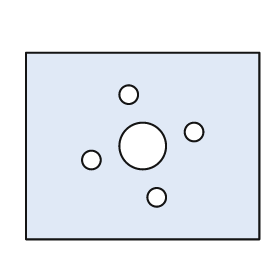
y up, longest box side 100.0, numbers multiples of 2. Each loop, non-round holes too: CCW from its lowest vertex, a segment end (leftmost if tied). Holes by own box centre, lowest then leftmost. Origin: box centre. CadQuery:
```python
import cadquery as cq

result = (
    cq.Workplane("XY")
    .moveTo(-50.0, -40.0)
    .lineTo(50.0, -40.0)
    .lineTo(50.0, 40.0)
    .lineTo(-50.0, 40.0)
    .close()
    .moveTo(6.0, -22.0)
    .circle(4.0)
    .moveTo(-22.0, -6.0)
    .circle(4.0)
    .moveTo(0.0, 0.0)
    .circle(10.0)
    .moveTo(22.0, 6.0)
    .circle(4.0)
    .moveTo(-6.0, 22.0)
    .circle(4.0)
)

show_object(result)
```